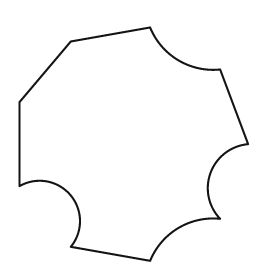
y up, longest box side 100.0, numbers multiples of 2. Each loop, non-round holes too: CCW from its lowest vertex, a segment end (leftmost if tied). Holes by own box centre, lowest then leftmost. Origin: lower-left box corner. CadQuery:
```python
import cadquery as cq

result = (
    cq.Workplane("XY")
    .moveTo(56.0, 0.0)
    .threePointArc((68.0, 14.0), (86.0, 18.0))
    .threePointArc((82.0, 38.0), (98.0, 50.0))
    .lineTo(86.0, 82.0)
    .threePointArc((68.0, 86.0), (56.0, 100.0))
    .lineTo(22.0, 94.0)
    .lineTo(0.0, 68.0)
    .lineTo(0.0, 32.0)
    .threePointArc((22.0, 28.0), (22.0, 6.0))
    .close()
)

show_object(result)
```